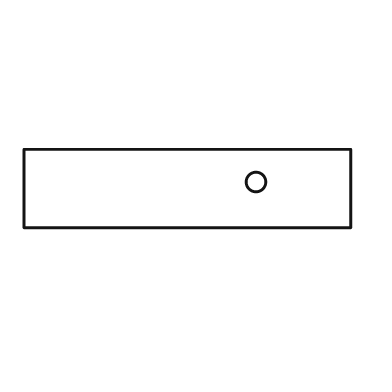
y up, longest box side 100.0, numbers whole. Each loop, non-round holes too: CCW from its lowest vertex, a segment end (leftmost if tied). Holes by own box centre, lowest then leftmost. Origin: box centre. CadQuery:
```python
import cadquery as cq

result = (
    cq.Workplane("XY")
    .moveTo(-50.0, -12.0)
    .lineTo(50.0, -12.0)
    .lineTo(50.0, 12.0)
    .lineTo(-50.0, 12.0)
    .close()
    .moveTo(21.0, 2.0)
    .circle(3.0)
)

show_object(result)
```